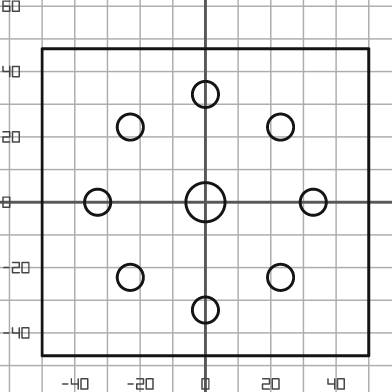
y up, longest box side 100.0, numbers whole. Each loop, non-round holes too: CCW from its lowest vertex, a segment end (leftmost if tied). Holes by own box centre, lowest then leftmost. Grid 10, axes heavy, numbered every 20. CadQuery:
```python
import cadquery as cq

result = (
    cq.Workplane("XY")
    .moveTo(-50.0, -47.0)
    .lineTo(50.0, -47.0)
    .lineTo(50.0, 47.0)
    .lineTo(-50.0, 47.0)
    .close()
    .moveTo(0.0, -33.0)
    .circle(4.0)
    .moveTo(-23.0, -23.0)
    .circle(4.0)
    .moveTo(23.0, -23.0)
    .circle(4.0)
    .moveTo(-33.0, 0.0)
    .circle(4.0)
    .moveTo(0.0, 0.0)
    .circle(6.0)
    .moveTo(33.0, 0.0)
    .circle(4.0)
    .moveTo(-23.0, 23.0)
    .circle(4.0)
    .moveTo(23.0, 23.0)
    .circle(4.0)
    .moveTo(0.0, 33.0)
    .circle(4.0)
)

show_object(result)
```